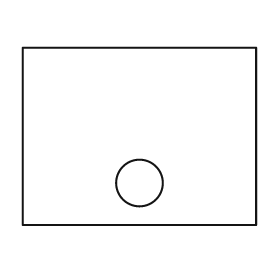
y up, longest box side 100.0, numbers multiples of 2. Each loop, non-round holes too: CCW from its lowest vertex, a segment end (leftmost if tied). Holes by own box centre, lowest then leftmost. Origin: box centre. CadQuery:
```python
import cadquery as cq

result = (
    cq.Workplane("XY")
    .moveTo(-50.0, -38.0)
    .lineTo(50.0, -38.0)
    .lineTo(50.0, 38.0)
    .lineTo(-50.0, 38.0)
    .close()
    .moveTo(0.0, -20.0)
    .circle(10.0)
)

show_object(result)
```